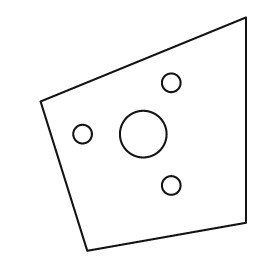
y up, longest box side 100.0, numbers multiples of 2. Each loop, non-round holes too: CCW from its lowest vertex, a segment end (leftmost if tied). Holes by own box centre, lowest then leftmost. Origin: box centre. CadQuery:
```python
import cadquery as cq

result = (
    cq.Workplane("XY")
    .moveTo(-24.0, -50.0)
    .lineTo(44.0, -38.0)
    .lineTo(44.0, 50.0)
    .lineTo(-44.0, 14.0)
    .close()
    .moveTo(12.0, -22.0)
    .circle(4.0)
    .moveTo(-26.0, 0.0)
    .circle(4.0)
    .moveTo(0.0, 0.0)
    .circle(10.0)
    .moveTo(12.0, 22.0)
    .circle(4.0)
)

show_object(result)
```